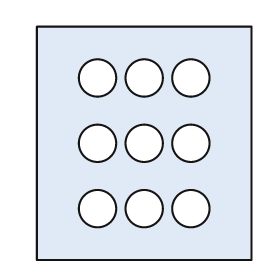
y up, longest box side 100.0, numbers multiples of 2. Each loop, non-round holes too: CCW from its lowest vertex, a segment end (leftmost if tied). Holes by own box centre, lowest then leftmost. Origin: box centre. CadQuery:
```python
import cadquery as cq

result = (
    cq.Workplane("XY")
    .moveTo(-46.0, -50.0)
    .lineTo(46.0, -50.0)
    .lineTo(46.0, 50.0)
    .lineTo(-46.0, 50.0)
    .close()
    .moveTo(-20.0, -28.0)
    .circle(8.0)
    .moveTo(0.0, -28.0)
    .circle(8.0)
    .moveTo(20.0, -28.0)
    .circle(8.0)
    .moveTo(-20.0, 0.0)
    .circle(8.0)
    .moveTo(0.0, 0.0)
    .circle(8.0)
    .moveTo(20.0, 0.0)
    .circle(8.0)
    .moveTo(-20.0, 28.0)
    .circle(8.0)
    .moveTo(0.0, 28.0)
    .circle(8.0)
    .moveTo(20.0, 28.0)
    .circle(8.0)
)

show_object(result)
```